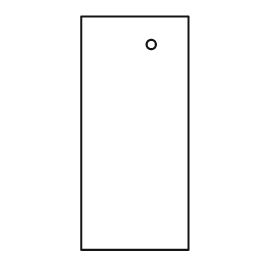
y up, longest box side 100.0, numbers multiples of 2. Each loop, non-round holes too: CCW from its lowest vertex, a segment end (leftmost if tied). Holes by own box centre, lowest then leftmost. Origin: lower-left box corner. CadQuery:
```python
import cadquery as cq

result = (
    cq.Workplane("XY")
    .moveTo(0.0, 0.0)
    .lineTo(46.0, 0.0)
    .lineTo(46.0, 100.0)
    .lineTo(0.0, 100.0)
    .close()
    .moveTo(30.0, 88.0)
    .circle(2.0)
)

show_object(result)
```